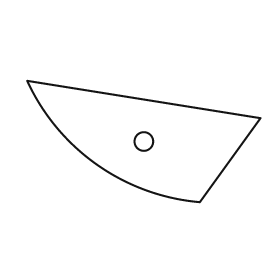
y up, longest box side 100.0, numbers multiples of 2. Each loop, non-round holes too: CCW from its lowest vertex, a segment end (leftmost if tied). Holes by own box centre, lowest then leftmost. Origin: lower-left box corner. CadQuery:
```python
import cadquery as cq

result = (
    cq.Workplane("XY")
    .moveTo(74.0, 0.0)
    .lineTo(100.0, 36.0)
    .lineTo(0.0, 52.0)
    .threePointArc((30.0, 16.0), (74.0, 0.0))
    .close()
    .moveTo(50.0, 26.0)
    .circle(4.0)
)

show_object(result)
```